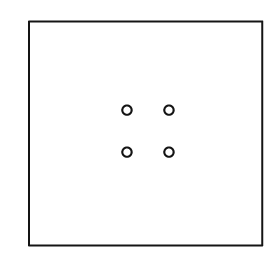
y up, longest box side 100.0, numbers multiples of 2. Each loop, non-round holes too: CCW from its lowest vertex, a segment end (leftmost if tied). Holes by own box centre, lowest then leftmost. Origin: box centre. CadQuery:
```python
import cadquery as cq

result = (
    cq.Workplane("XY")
    .moveTo(-50.0, -48.0)
    .lineTo(50.0, -48.0)
    .lineTo(50.0, 48.0)
    .lineTo(-50.0, 48.0)
    .close()
    .moveTo(-8.0, -8.0)
    .circle(2.0)
    .moveTo(10.0, -8.0)
    .circle(2.0)
    .moveTo(-8.0, 10.0)
    .circle(2.0)
    .moveTo(10.0, 10.0)
    .circle(2.0)
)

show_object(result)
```